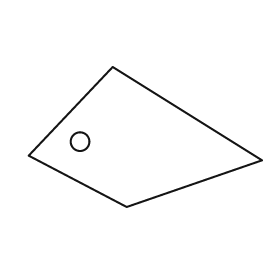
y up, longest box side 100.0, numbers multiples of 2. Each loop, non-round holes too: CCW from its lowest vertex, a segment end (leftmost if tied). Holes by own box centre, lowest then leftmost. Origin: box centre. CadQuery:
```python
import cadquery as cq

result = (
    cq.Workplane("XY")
    .moveTo(-8.0, -30.0)
    .lineTo(50.0, -10.0)
    .lineTo(-14.0, 30.0)
    .lineTo(-50.0, -8.0)
    .close()
    .moveTo(-28.0, -2.0)
    .circle(4.0)
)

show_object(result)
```